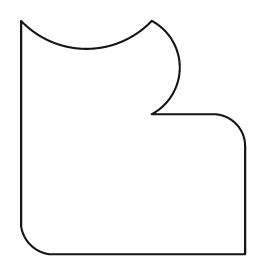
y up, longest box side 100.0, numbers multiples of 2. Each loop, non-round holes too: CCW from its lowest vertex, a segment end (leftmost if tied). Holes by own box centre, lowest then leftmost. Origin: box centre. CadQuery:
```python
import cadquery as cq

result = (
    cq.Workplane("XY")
    .moveTo(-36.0, -50.0)
    .lineTo(48.0, -50.0)
    .lineTo(48.0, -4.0)
    .threePointArc((44.0, 6.0), (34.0, 10.0))
    .lineTo(8.0, 10.0)
    .threePointArc((20.0, 30.0), (8.0, 50.0))
    .threePointArc((-20.0, 38.0), (-48.0, 50.0))
    .lineTo(-48.0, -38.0)
    .threePointArc((-44.0, -46.0), (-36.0, -50.0))
    .close()
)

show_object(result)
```